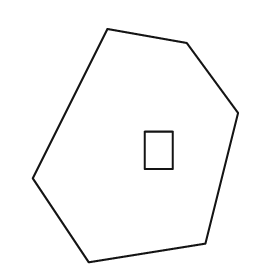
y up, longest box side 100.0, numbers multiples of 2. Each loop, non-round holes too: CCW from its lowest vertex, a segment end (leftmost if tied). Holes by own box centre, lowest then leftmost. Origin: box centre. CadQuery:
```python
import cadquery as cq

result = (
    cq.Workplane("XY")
    .moveTo(-20.0, -50.0)
    .lineTo(30.0, -42.0)
    .lineTo(44.0, 14.0)
    .lineTo(22.0, 44.0)
    .lineTo(-12.0, 50.0)
    .lineTo(-44.0, -14.0)
    .close()
    .moveTo(4.0, -10.0)
    .lineTo(16.0, -10.0)
    .lineTo(16.0, 6.0)
    .lineTo(4.0, 6.0)
    .close()
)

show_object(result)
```